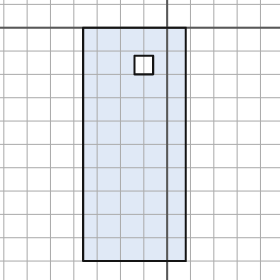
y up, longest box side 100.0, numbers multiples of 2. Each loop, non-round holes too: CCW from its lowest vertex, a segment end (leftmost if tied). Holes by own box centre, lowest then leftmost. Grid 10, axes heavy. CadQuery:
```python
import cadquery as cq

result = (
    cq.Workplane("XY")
    .moveTo(-36.0, -100.0)
    .lineTo(8.0, -100.0)
    .lineTo(8.0, 0.0)
    .lineTo(-36.0, 0.0)
    .close()
    .moveTo(-14.0, -20.0)
    .lineTo(-6.0, -20.0)
    .lineTo(-6.0, -12.0)
    .lineTo(-14.0, -12.0)
    .close()
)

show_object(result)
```